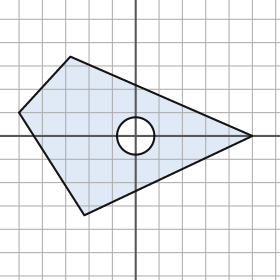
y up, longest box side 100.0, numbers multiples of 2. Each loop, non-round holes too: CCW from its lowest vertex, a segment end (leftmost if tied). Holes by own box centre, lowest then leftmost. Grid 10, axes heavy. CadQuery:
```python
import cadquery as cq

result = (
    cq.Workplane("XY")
    .moveTo(-22.0, -34.0)
    .lineTo(50.0, 0.0)
    .lineTo(-28.0, 34.0)
    .lineTo(-50.0, 10.0)
    .close()
    .moveTo(0.0, 0.0)
    .circle(8.0)
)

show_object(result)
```